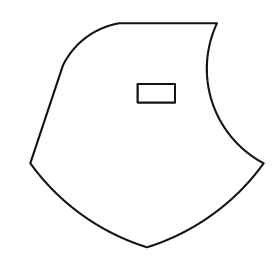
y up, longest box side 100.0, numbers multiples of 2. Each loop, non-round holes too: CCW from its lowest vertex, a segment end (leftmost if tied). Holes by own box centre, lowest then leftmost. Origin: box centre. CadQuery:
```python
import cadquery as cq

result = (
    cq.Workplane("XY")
    .moveTo(0.0, -48.0)
    .threePointArc((28.0, -34.0), (50.0, -12.0))
    .threePointArc((28.0, 14.0), (30.0, 48.0))
    .lineTo(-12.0, 48.0)
    .threePointArc((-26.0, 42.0), (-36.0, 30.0))
    .lineTo(-50.0, -12.0)
    .threePointArc((-28.0, -34.0), (0.0, -48.0))
    .close()
    .moveTo(-4.0, 14.0)
    .lineTo(12.0, 14.0)
    .lineTo(12.0, 22.0)
    .lineTo(-4.0, 22.0)
    .close()
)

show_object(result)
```